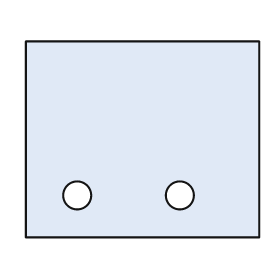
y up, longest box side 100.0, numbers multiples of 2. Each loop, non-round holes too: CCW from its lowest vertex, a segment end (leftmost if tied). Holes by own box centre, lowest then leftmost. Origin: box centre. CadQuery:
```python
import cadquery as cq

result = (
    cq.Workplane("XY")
    .moveTo(-50.0, -42.0)
    .lineTo(50.0, -42.0)
    .lineTo(50.0, 42.0)
    .lineTo(-50.0, 42.0)
    .close()
    .moveTo(-28.0, -24.0)
    .circle(6.0)
    .moveTo(16.0, -24.0)
    .circle(6.0)
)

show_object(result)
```